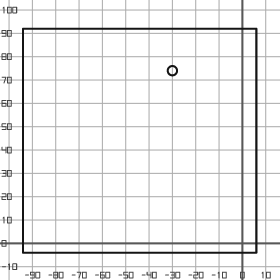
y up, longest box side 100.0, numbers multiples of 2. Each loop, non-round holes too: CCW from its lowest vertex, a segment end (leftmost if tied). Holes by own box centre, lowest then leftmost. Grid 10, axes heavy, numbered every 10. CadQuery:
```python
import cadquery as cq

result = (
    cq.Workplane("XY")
    .moveTo(-94.0, -4.0)
    .lineTo(6.0, -4.0)
    .lineTo(6.0, 92.0)
    .lineTo(-94.0, 92.0)
    .close()
    .moveTo(-30.0, 74.0)
    .circle(2.0)
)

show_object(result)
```